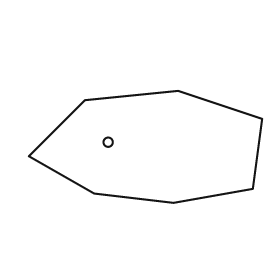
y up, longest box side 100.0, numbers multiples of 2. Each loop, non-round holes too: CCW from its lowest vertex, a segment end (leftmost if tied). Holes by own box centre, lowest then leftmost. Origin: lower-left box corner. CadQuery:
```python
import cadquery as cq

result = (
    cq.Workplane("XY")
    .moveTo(62.0, 0.0)
    .lineTo(96.0, 6.0)
    .lineTo(100.0, 36.0)
    .lineTo(64.0, 48.0)
    .lineTo(24.0, 44.0)
    .lineTo(0.0, 20.0)
    .lineTo(28.0, 4.0)
    .close()
    .moveTo(34.0, 26.0)
    .circle(2.0)
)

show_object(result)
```